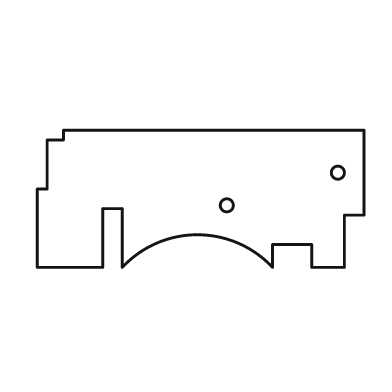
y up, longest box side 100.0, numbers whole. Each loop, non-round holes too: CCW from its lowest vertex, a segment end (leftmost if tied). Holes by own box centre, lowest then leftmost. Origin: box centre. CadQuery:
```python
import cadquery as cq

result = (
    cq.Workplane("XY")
    .moveTo(-50.0, -21.0)
    .lineTo(-30.0, -21.0)
    .lineTo(-30.0, -3.0)
    .lineTo(-24.0, -3.0)
    .lineTo(-24.0, -21.0)
    .threePointArc((-1.0, -11.0), (22.0, -21.0))
    .lineTo(22.0, -14.0)
    .lineTo(34.0, -14.0)
    .lineTo(34.0, -21.0)
    .lineTo(44.0, -21.0)
    .lineTo(44.0, -5.0)
    .lineTo(50.0, -5.0)
    .lineTo(50.0, 21.0)
    .lineTo(-42.0, 21.0)
    .lineTo(-42.0, 18.0)
    .lineTo(-47.0, 18.0)
    .lineTo(-47.0, 3.0)
    .lineTo(-50.0, 3.0)
    .close()
    .moveTo(8.0, -2.0)
    .circle(2.0)
    .moveTo(42.0, 8.0)
    .circle(2.0)
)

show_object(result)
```